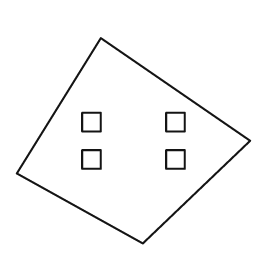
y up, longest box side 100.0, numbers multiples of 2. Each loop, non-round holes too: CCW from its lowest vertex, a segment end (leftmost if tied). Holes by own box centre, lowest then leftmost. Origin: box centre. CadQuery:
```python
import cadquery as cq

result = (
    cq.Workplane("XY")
    .moveTo(4.0, -44.0)
    .lineTo(50.0, 0.0)
    .lineTo(-14.0, 44.0)
    .lineTo(-50.0, -14.0)
    .close()
    .moveTo(-22.0, -12.0)
    .lineTo(-14.0, -12.0)
    .lineTo(-14.0, -4.0)
    .lineTo(-22.0, -4.0)
    .close()
    .moveTo(14.0, -12.0)
    .lineTo(22.0, -12.0)
    .lineTo(22.0, -4.0)
    .lineTo(14.0, -4.0)
    .close()
    .moveTo(-22.0, 4.0)
    .lineTo(-14.0, 4.0)
    .lineTo(-14.0, 12.0)
    .lineTo(-22.0, 12.0)
    .close()
    .moveTo(14.0, 4.0)
    .lineTo(22.0, 4.0)
    .lineTo(22.0, 12.0)
    .lineTo(14.0, 12.0)
    .close()
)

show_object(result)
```